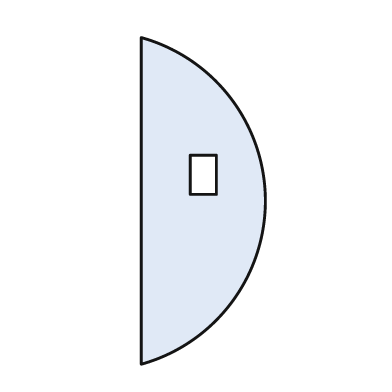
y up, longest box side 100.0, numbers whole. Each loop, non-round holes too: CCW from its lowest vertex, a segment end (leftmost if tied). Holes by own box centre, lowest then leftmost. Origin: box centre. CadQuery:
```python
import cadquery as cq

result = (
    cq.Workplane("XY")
    .moveTo(-19.0, -50.0)
    .threePointArc((19.0, 0.0), (-19.0, 50.0))
    .close()
    .moveTo(-4.0, 2.0)
    .lineTo(4.0, 2.0)
    .lineTo(4.0, 14.0)
    .lineTo(-4.0, 14.0)
    .close()
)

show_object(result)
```